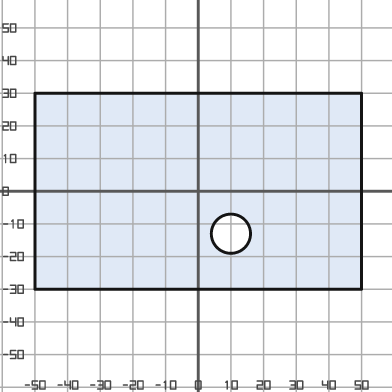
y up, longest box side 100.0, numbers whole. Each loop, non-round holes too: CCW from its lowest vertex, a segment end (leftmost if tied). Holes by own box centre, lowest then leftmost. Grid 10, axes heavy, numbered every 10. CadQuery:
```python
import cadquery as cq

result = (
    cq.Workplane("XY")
    .moveTo(-50.0, -30.0)
    .lineTo(50.0, -30.0)
    .lineTo(50.0, 30.0)
    .lineTo(-50.0, 30.0)
    .close()
    .moveTo(10.0, -13.0)
    .circle(6.0)
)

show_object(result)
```